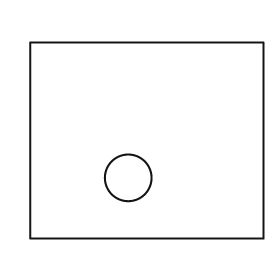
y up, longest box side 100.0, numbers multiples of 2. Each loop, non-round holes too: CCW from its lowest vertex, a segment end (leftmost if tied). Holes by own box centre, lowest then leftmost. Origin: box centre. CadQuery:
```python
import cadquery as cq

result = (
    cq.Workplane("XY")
    .moveTo(-50.0, -42.0)
    .lineTo(50.0, -42.0)
    .lineTo(50.0, 42.0)
    .lineTo(-50.0, 42.0)
    .close()
    .moveTo(-8.0, -16.0)
    .circle(10.0)
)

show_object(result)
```